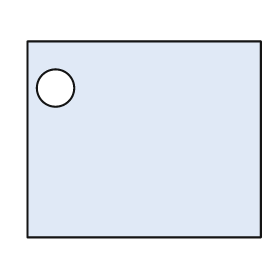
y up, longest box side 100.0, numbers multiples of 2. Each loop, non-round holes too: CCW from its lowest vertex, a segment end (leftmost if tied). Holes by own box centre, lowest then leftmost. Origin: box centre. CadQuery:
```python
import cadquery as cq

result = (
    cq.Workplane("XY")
    .moveTo(-50.0, -42.0)
    .lineTo(50.0, -42.0)
    .lineTo(50.0, 42.0)
    .lineTo(-50.0, 42.0)
    .close()
    .moveTo(-38.0, 22.0)
    .circle(8.0)
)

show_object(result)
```